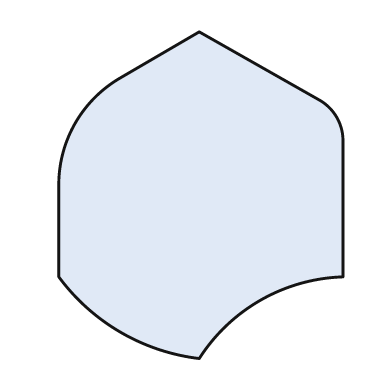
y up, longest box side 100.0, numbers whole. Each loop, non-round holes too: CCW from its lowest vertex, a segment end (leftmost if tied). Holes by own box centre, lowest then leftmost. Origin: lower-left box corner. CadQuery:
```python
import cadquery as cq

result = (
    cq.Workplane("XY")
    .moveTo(43.0, 0.0)
    .threePointArc((62.0, 18.0), (87.0, 25.0))
    .lineTo(87.0, 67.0)
    .threePointArc((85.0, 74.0), (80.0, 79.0))
    .lineTo(43.0, 100.0)
    .lineTo(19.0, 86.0)
    .threePointArc((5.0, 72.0), (0.0, 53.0))
    .lineTo(0.0, 25.0)
    .threePointArc((19.0, 8.0), (43.0, 0.0))
    .close()
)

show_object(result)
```